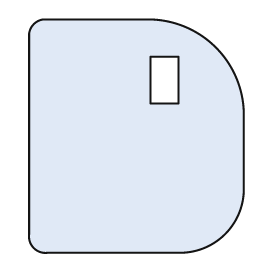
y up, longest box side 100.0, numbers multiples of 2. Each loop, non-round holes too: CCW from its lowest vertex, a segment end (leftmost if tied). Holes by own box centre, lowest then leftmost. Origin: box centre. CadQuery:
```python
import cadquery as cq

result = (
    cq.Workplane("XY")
    .moveTo(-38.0, -50.0)
    .lineTo(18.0, -50.0)
    .threePointArc((38.0, -42.0), (46.0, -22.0))
    .lineTo(46.0, 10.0)
    .threePointArc((34.0, 38.0), (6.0, 50.0))
    .lineTo(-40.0, 50.0)
    .threePointArc((-44.0, 48.0), (-46.0, 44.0))
    .lineTo(-46.0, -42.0)
    .threePointArc((-44.0, -48.0), (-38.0, -50.0))
    .close()
    .moveTo(6.0, 14.0)
    .lineTo(18.0, 14.0)
    .lineTo(18.0, 34.0)
    .lineTo(6.0, 34.0)
    .close()
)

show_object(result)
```